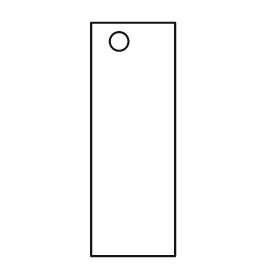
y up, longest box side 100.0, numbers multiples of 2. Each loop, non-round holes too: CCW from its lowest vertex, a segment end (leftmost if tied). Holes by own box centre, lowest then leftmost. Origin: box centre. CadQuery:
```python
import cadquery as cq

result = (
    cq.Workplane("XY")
    .moveTo(-18.0, -50.0)
    .lineTo(18.0, -50.0)
    .lineTo(18.0, 50.0)
    .lineTo(-18.0, 50.0)
    .close()
    .moveTo(-6.0, 42.0)
    .circle(4.0)
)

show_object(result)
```